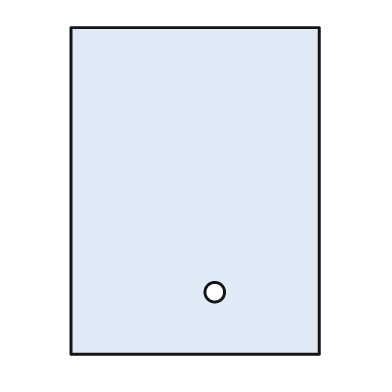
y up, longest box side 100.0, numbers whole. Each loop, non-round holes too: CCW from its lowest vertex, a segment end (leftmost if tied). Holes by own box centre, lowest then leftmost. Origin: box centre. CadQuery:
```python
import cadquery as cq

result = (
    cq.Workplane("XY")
    .moveTo(-38.0, -50.0)
    .lineTo(38.0, -50.0)
    .lineTo(38.0, 50.0)
    .lineTo(-38.0, 50.0)
    .close()
    .moveTo(6.0, -31.0)
    .circle(3.0)
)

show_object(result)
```